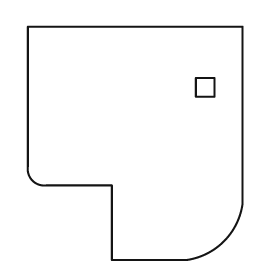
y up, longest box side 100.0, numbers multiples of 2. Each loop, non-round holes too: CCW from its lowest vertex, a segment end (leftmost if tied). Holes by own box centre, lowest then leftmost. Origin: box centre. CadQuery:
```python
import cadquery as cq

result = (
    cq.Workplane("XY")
    .moveTo(-10.0, -50.0)
    .lineTo(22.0, -50.0)
    .threePointArc((38.0, -42.0), (46.0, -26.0))
    .lineTo(46.0, 50.0)
    .lineTo(-46.0, 50.0)
    .lineTo(-46.0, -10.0)
    .threePointArc((-44.0, -16.0), (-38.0, -18.0))
    .lineTo(-10.0, -18.0)
    .close()
    .moveTo(26.0, 20.0)
    .lineTo(34.0, 20.0)
    .lineTo(34.0, 28.0)
    .lineTo(26.0, 28.0)
    .close()
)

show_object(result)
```